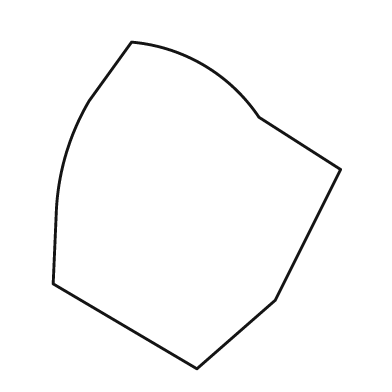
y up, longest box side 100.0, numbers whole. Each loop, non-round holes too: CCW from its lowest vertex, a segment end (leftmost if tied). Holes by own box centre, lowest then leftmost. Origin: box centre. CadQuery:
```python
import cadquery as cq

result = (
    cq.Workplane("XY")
    .moveTo(0.0, -50.0)
    .lineTo(24.0, -29.0)
    .lineTo(44.0, 11.0)
    .lineTo(19.0, 27.0)
    .threePointArc((2.0, 43.0), (-20.0, 50.0))
    .lineTo(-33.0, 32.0)
    .threePointArc((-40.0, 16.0), (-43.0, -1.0))
    .lineTo(-44.0, -24.0)
    .close()
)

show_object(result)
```